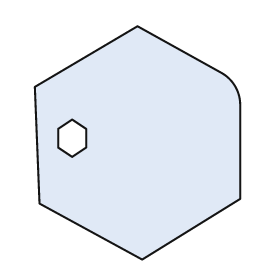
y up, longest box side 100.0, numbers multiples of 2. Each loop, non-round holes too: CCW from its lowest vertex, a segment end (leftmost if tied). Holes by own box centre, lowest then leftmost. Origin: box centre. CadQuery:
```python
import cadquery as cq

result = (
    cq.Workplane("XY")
    .moveTo(2.0, -50.0)
    .lineTo(44.0, -24.0)
    .lineTo(44.0, 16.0)
    .threePointArc((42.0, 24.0), (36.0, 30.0))
    .lineTo(0.0, 50.0)
    .lineTo(-44.0, 24.0)
    .lineTo(-42.0, -26.0)
    .close()
    .moveTo(-28.0, -6.0)
    .lineTo(-22.0, -2.0)
    .lineTo(-22.0, 6.0)
    .lineTo(-28.0, 10.0)
    .lineTo(-34.0, 6.0)
    .lineTo(-34.0, -2.0)
    .close()
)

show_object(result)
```